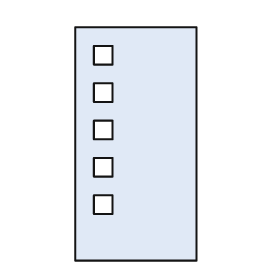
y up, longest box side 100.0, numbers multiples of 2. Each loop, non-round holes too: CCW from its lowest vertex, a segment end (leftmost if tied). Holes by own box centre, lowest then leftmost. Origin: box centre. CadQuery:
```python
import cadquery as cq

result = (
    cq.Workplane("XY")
    .moveTo(-26.0, -50.0)
    .lineTo(26.0, -50.0)
    .lineTo(26.0, 50.0)
    .lineTo(-26.0, 50.0)
    .close()
    .moveTo(-18.0, -30.0)
    .lineTo(-10.0, -30.0)
    .lineTo(-10.0, -22.0)
    .lineTo(-18.0, -22.0)
    .close()
    .moveTo(-18.0, -14.0)
    .lineTo(-10.0, -14.0)
    .lineTo(-10.0, -6.0)
    .lineTo(-18.0, -6.0)
    .close()
    .moveTo(-18.0, 2.0)
    .lineTo(-10.0, 2.0)
    .lineTo(-10.0, 10.0)
    .lineTo(-18.0, 10.0)
    .close()
    .moveTo(-18.0, 18.0)
    .lineTo(-10.0, 18.0)
    .lineTo(-10.0, 26.0)
    .lineTo(-18.0, 26.0)
    .close()
    .moveTo(-18.0, 34.0)
    .lineTo(-10.0, 34.0)
    .lineTo(-10.0, 42.0)
    .lineTo(-18.0, 42.0)
    .close()
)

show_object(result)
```